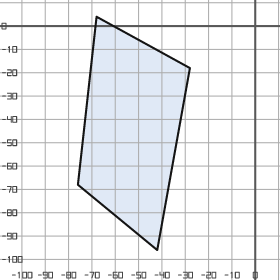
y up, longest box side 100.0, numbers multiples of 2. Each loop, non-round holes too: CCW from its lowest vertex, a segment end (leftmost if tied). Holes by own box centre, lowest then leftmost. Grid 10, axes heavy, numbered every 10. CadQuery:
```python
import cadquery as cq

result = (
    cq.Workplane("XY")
    .moveTo(-42.0, -96.0)
    .lineTo(-28.0, -18.0)
    .lineTo(-68.0, 4.0)
    .lineTo(-76.0, -68.0)
    .close()
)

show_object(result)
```